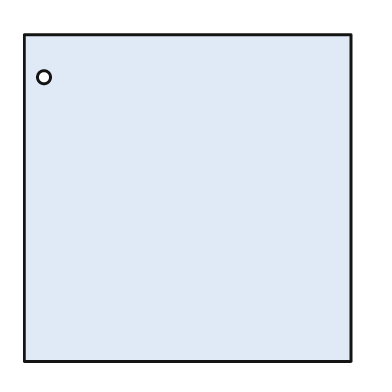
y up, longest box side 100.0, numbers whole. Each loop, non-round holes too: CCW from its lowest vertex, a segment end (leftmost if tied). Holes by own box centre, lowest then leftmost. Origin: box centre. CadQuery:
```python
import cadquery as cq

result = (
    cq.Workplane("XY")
    .moveTo(-50.0, -50.0)
    .lineTo(50.0, -50.0)
    .lineTo(50.0, 50.0)
    .lineTo(-50.0, 50.0)
    .close()
    .moveTo(-44.0, 37.0)
    .circle(2.0)
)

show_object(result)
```